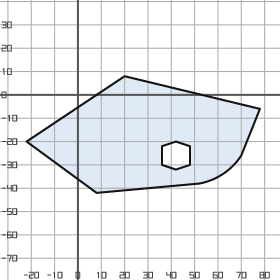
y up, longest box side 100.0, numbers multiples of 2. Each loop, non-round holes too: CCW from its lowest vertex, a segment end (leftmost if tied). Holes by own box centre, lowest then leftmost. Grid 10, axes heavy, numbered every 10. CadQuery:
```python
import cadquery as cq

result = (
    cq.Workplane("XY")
    .moveTo(8.0, -42.0)
    .lineTo(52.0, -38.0)
    .threePointArc((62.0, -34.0), (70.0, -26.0))
    .lineTo(78.0, -6.0)
    .lineTo(20.0, 8.0)
    .lineTo(-22.0, -20.0)
    .close()
    .moveTo(42.0, -32.0)
    .lineTo(48.0, -30.0)
    .lineTo(48.0, -22.0)
    .lineTo(42.0, -20.0)
    .lineTo(36.0, -22.0)
    .lineTo(36.0, -30.0)
    .close()
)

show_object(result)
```